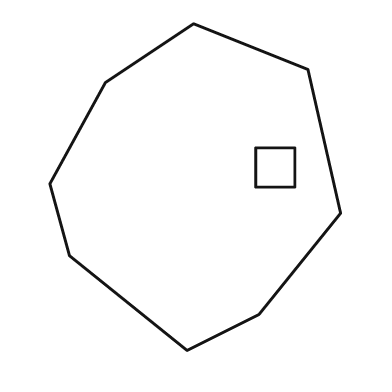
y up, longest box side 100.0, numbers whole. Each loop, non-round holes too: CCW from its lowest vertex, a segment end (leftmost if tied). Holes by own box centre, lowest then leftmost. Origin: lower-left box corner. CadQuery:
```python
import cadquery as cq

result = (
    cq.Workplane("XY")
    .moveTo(42.0, 0.0)
    .lineTo(64.0, 11.0)
    .lineTo(89.0, 42.0)
    .lineTo(79.0, 86.0)
    .lineTo(44.0, 100.0)
    .lineTo(17.0, 82.0)
    .lineTo(0.0, 51.0)
    .lineTo(6.0, 29.0)
    .close()
    .moveTo(63.0, 50.0)
    .lineTo(75.0, 50.0)
    .lineTo(75.0, 62.0)
    .lineTo(63.0, 62.0)
    .close()
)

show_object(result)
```